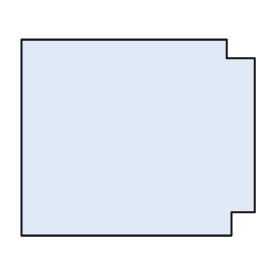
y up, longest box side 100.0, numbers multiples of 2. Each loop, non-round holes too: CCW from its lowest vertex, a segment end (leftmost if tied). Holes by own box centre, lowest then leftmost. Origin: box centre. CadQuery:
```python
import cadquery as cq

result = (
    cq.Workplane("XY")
    .moveTo(-50.0, -42.0)
    .lineTo(40.0, -42.0)
    .lineTo(40.0, -32.0)
    .lineTo(50.0, -32.0)
    .lineTo(50.0, 34.0)
    .lineTo(38.0, 34.0)
    .lineTo(38.0, 42.0)
    .lineTo(-50.0, 42.0)
    .close()
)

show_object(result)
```